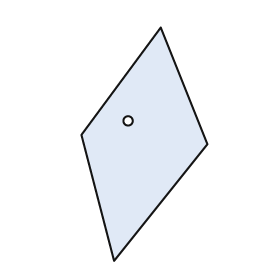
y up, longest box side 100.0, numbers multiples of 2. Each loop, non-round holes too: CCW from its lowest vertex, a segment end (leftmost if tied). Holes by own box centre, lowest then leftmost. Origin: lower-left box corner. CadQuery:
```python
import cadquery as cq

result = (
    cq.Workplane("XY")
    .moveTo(14.0, 0.0)
    .lineTo(54.0, 50.0)
    .lineTo(34.0, 100.0)
    .lineTo(0.0, 54.0)
    .close()
    .moveTo(20.0, 60.0)
    .circle(2.0)
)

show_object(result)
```